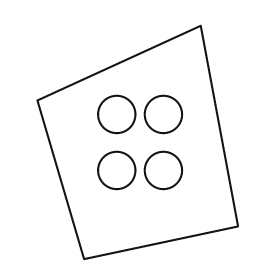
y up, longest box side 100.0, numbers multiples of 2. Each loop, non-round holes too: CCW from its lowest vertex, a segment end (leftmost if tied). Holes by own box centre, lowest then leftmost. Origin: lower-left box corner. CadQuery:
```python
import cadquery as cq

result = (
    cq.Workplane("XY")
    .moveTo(20.0, 0.0)
    .lineTo(86.0, 14.0)
    .lineTo(70.0, 100.0)
    .lineTo(0.0, 68.0)
    .close()
    .moveTo(34.0, 38.0)
    .circle(8.0)
    .moveTo(54.0, 38.0)
    .circle(8.0)
    .moveTo(34.0, 62.0)
    .circle(8.0)
    .moveTo(54.0, 62.0)
    .circle(8.0)
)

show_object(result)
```